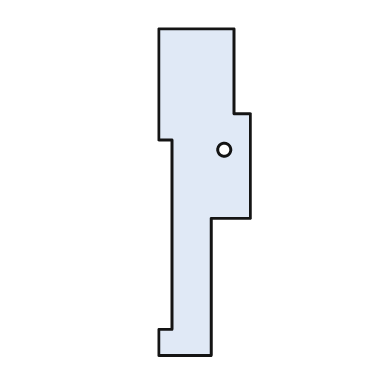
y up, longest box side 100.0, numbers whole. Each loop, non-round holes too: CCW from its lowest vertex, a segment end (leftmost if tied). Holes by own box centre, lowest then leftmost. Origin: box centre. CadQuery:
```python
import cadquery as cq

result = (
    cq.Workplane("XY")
    .moveTo(-14.0, -50.0)
    .lineTo(2.0, -50.0)
    .lineTo(2.0, -8.0)
    .lineTo(14.0, -8.0)
    .lineTo(14.0, 24.0)
    .lineTo(9.0, 24.0)
    .lineTo(9.0, 50.0)
    .lineTo(-14.0, 50.0)
    .lineTo(-14.0, 16.0)
    .lineTo(-10.0, 16.0)
    .lineTo(-10.0, -42.0)
    .lineTo(-14.0, -42.0)
    .close()
    .moveTo(6.0, 13.0)
    .circle(2.0)
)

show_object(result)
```